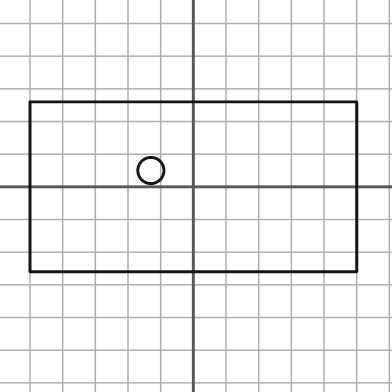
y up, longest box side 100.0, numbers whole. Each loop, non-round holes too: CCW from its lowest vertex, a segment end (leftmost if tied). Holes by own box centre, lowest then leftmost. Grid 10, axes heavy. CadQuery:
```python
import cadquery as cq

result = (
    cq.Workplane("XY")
    .moveTo(-50.0, -26.0)
    .lineTo(50.0, -26.0)
    .lineTo(50.0, 26.0)
    .lineTo(-50.0, 26.0)
    .close()
    .moveTo(-13.0, 5.0)
    .circle(4.0)
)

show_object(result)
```